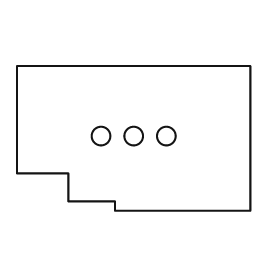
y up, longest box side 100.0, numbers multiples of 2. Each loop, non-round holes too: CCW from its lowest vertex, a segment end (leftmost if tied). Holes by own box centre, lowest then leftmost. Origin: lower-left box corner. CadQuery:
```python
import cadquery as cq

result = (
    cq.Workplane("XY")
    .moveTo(42.0, 0.0)
    .lineTo(100.0, 0.0)
    .lineTo(100.0, 62.0)
    .lineTo(0.0, 62.0)
    .lineTo(0.0, 16.0)
    .lineTo(22.0, 16.0)
    .lineTo(22.0, 4.0)
    .lineTo(42.0, 4.0)
    .close()
    .moveTo(36.0, 32.0)
    .circle(4.0)
    .moveTo(50.0, 32.0)
    .circle(4.0)
    .moveTo(64.0, 32.0)
    .circle(4.0)
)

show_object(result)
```